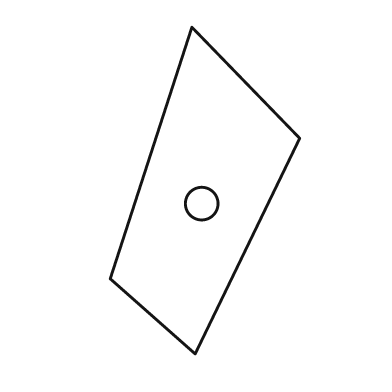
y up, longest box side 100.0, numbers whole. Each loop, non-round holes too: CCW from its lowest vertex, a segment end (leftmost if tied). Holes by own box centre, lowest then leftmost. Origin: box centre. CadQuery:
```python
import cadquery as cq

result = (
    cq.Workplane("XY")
    .moveTo(-3.0, -50.0)
    .lineTo(29.0, 16.0)
    .lineTo(-4.0, 50.0)
    .lineTo(-29.0, -27.0)
    .close()
    .moveTo(-1.0, -4.0)
    .circle(5.0)
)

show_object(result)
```